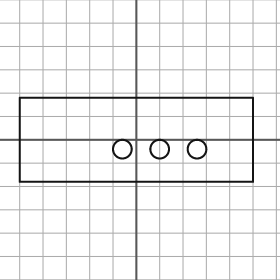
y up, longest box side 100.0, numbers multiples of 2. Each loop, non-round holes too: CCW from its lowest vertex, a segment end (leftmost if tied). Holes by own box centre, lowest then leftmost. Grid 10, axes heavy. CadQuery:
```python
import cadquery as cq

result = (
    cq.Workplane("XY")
    .moveTo(-50.0, -18.0)
    .lineTo(50.0, -18.0)
    .lineTo(50.0, 18.0)
    .lineTo(-50.0, 18.0)
    .close()
    .moveTo(-6.0, -4.0)
    .circle(4.0)
    .moveTo(10.0, -4.0)
    .circle(4.0)
    .moveTo(26.0, -4.0)
    .circle(4.0)
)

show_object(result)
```